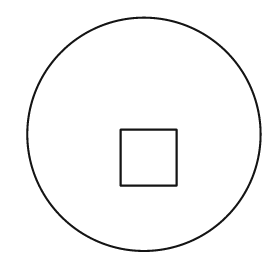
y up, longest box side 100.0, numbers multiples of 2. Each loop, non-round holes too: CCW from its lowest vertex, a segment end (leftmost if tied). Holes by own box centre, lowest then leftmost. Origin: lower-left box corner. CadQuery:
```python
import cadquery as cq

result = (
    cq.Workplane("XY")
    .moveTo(50.0, 50.0)
    .circle(50.0)
    .moveTo(40.0, 28.0)
    .lineTo(64.0, 28.0)
    .lineTo(64.0, 52.0)
    .lineTo(40.0, 52.0)
    .close()
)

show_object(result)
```